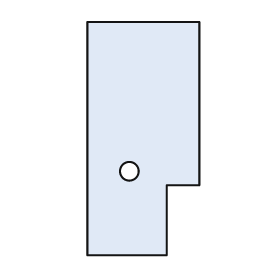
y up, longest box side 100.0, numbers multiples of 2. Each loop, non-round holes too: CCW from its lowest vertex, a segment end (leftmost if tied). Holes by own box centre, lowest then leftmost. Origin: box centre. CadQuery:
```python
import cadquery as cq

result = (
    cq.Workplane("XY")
    .moveTo(-24.0, -50.0)
    .lineTo(10.0, -50.0)
    .lineTo(10.0, -20.0)
    .lineTo(24.0, -20.0)
    .lineTo(24.0, 50.0)
    .lineTo(-24.0, 50.0)
    .close()
    .moveTo(-6.0, -14.0)
    .circle(4.0)
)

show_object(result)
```